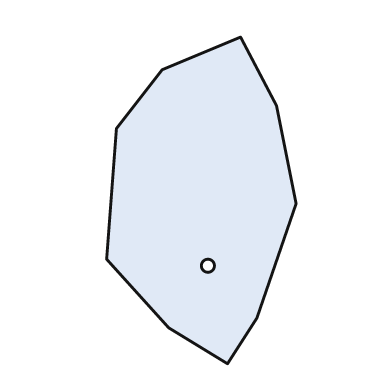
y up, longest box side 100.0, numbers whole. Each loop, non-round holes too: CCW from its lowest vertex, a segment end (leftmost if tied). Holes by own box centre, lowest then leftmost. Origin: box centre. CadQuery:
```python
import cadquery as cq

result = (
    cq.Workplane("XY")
    .moveTo(8.0, -50.0)
    .lineTo(17.0, -36.0)
    .lineTo(29.0, -1.0)
    .lineTo(23.0, 29.0)
    .lineTo(12.0, 50.0)
    .lineTo(-12.0, 40.0)
    .lineTo(-26.0, 22.0)
    .lineTo(-29.0, -18.0)
    .lineTo(-10.0, -39.0)
    .close()
    .moveTo(2.0, -20.0)
    .circle(2.0)
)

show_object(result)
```